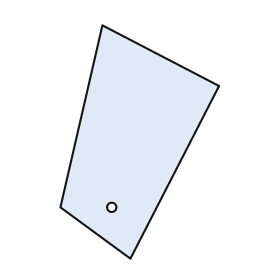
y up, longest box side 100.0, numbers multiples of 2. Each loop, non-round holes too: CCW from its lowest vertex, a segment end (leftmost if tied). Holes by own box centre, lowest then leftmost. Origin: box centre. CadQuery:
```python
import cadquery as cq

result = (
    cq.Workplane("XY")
    .moveTo(-4.0, -50.0)
    .lineTo(34.0, 24.0)
    .lineTo(-16.0, 50.0)
    .lineTo(-34.0, -28.0)
    .close()
    .moveTo(-12.0, -28.0)
    .circle(2.0)
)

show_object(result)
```